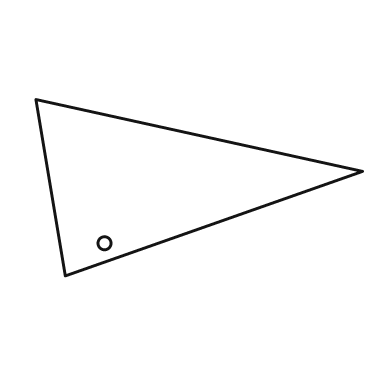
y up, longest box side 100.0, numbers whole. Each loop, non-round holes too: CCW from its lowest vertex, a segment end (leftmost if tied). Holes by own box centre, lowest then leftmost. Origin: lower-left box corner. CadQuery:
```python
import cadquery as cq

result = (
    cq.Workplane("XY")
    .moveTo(9.0, 0.0)
    .lineTo(100.0, 32.0)
    .lineTo(0.0, 54.0)
    .close()
    .moveTo(21.0, 10.0)
    .circle(2.0)
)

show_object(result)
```